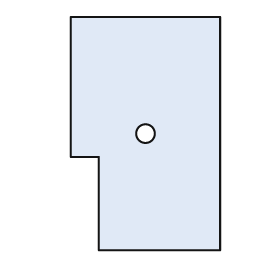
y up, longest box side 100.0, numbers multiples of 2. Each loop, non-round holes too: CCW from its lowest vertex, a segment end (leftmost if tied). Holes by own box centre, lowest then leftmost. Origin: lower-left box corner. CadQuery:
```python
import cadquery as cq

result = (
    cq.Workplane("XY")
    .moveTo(12.0, 0.0)
    .lineTo(64.0, 0.0)
    .lineTo(64.0, 100.0)
    .lineTo(0.0, 100.0)
    .lineTo(0.0, 40.0)
    .lineTo(12.0, 40.0)
    .close()
    .moveTo(32.0, 50.0)
    .circle(4.0)
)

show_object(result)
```